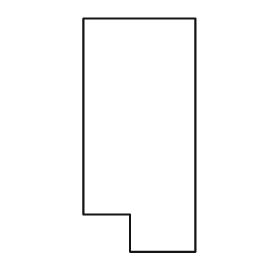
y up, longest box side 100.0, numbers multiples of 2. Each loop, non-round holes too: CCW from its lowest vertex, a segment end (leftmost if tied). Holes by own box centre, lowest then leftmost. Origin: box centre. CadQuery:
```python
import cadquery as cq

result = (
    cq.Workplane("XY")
    .moveTo(-4.0, -50.0)
    .lineTo(24.0, -50.0)
    .lineTo(24.0, 50.0)
    .lineTo(-24.0, 50.0)
    .lineTo(-24.0, -34.0)
    .lineTo(-4.0, -34.0)
    .close()
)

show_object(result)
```